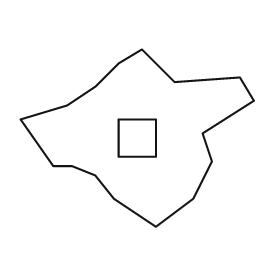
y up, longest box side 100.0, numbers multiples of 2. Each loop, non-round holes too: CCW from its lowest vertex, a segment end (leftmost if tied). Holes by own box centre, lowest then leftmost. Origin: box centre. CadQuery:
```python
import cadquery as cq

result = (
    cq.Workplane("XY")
    .moveTo(8.0, -38.0)
    .lineTo(24.0, -26.0)
    .lineTo(32.0, -10.0)
    .lineTo(28.0, 2.0)
    .lineTo(50.0, 16.0)
    .lineTo(44.0, 26.0)
    .lineTo(16.0, 24.0)
    .lineTo(2.0, 38.0)
    .lineTo(-8.0, 32.0)
    .lineTo(-18.0, 22.0)
    .lineTo(-30.0, 14.0)
    .lineTo(-50.0, 8.0)
    .lineTo(-36.0, -12.0)
    .lineTo(-28.0, -12.0)
    .lineTo(-18.0, -16.0)
    .lineTo(-10.0, -26.0)
    .close()
    .moveTo(-8.0, -8.0)
    .lineTo(8.0, -8.0)
    .lineTo(8.0, 8.0)
    .lineTo(-8.0, 8.0)
    .close()
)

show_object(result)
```